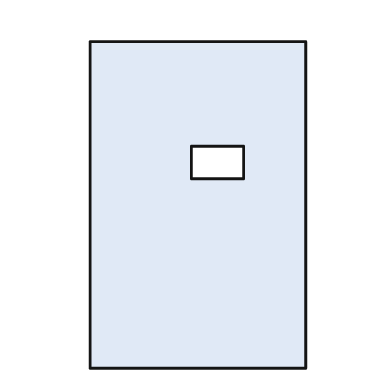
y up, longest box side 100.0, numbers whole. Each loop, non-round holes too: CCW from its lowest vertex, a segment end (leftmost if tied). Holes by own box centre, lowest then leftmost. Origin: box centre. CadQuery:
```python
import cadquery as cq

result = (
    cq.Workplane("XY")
    .moveTo(-33.0, -50.0)
    .lineTo(33.0, -50.0)
    .lineTo(33.0, 50.0)
    .lineTo(-33.0, 50.0)
    .close()
    .moveTo(-2.0, 8.0)
    .lineTo(14.0, 8.0)
    .lineTo(14.0, 18.0)
    .lineTo(-2.0, 18.0)
    .close()
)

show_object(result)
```